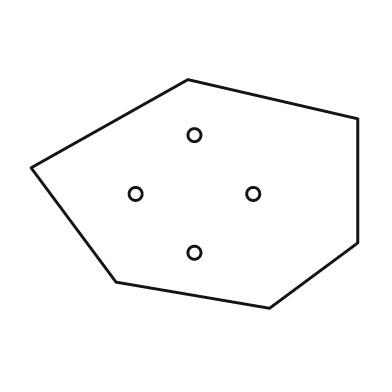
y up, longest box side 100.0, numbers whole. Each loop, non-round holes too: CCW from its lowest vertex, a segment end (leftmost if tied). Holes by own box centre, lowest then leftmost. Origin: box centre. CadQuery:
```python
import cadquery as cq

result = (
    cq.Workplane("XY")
    .moveTo(23.0, -35.0)
    .lineTo(50.0, -15.0)
    .lineTo(50.0, 23.0)
    .lineTo(-2.0, 35.0)
    .lineTo(-50.0, 8.0)
    .lineTo(-24.0, -27.0)
    .close()
    .moveTo(0.0, -18.0)
    .circle(2.0)
    .moveTo(-18.0, 0.0)
    .circle(2.0)
    .moveTo(18.0, 0.0)
    .circle(2.0)
    .moveTo(0.0, 18.0)
    .circle(2.0)
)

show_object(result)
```